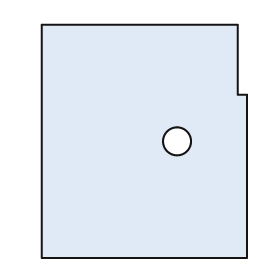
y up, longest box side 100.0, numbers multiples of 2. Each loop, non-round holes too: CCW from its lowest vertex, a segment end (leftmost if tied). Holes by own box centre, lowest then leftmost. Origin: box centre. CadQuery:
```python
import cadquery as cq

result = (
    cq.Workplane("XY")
    .moveTo(-44.0, -50.0)
    .lineTo(44.0, -50.0)
    .lineTo(44.0, 20.0)
    .lineTo(40.0, 20.0)
    .lineTo(40.0, 50.0)
    .lineTo(-44.0, 50.0)
    .close()
    .moveTo(14.0, 0.0)
    .circle(6.0)
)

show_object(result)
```